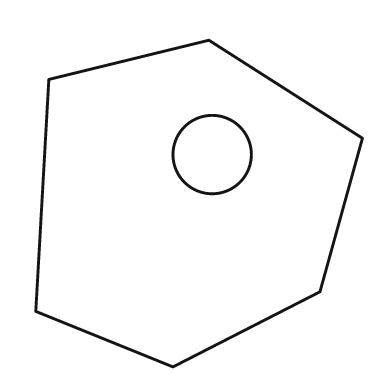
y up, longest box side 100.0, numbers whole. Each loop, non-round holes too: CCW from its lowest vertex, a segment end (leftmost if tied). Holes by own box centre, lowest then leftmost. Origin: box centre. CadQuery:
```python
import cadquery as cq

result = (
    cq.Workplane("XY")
    .moveTo(-8.0, -50.0)
    .lineTo(37.0, -27.0)
    .lineTo(50.0, 20.0)
    .lineTo(3.0, 50.0)
    .lineTo(-46.0, 38.0)
    .lineTo(-50.0, -33.0)
    .close()
    .moveTo(4.0, 15.0)
    .circle(12.0)
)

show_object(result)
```